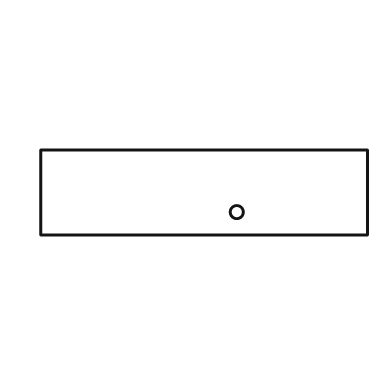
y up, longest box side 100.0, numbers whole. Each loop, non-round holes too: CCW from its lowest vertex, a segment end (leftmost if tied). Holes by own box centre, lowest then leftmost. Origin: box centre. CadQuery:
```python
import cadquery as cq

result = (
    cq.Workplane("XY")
    .moveTo(-50.0, -13.0)
    .lineTo(50.0, -13.0)
    .lineTo(50.0, 13.0)
    .lineTo(-50.0, 13.0)
    .close()
    .moveTo(10.0, -6.0)
    .circle(2.0)
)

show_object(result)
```